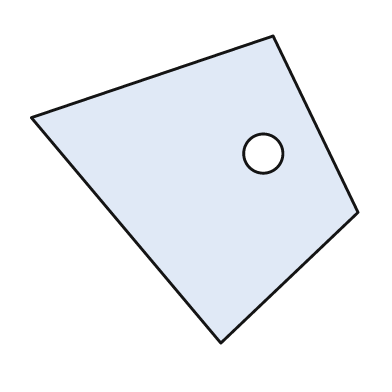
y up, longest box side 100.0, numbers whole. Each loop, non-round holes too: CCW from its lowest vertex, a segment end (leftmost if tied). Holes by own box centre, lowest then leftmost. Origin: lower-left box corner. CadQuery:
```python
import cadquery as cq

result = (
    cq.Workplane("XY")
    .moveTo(58.0, 0.0)
    .lineTo(100.0, 40.0)
    .lineTo(74.0, 94.0)
    .lineTo(0.0, 69.0)
    .close()
    .moveTo(71.0, 58.0)
    .circle(6.0)
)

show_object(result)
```